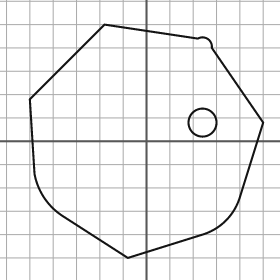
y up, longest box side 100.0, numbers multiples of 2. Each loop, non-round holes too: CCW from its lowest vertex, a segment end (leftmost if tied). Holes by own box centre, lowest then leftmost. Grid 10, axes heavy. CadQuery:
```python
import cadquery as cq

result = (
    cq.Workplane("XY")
    .moveTo(-8.0, -50.0)
    .lineTo(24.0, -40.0)
    .threePointArc((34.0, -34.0), (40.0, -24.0))
    .lineTo(50.0, 8.0)
    .lineTo(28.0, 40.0)
    .threePointArc((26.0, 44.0), (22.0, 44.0))
    .lineTo(-18.0, 50.0)
    .lineTo(-50.0, 18.0)
    .lineTo(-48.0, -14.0)
    .threePointArc((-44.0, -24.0), (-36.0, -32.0))
    .close()
    .moveTo(24.0, 8.0)
    .circle(6.0)
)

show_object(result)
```